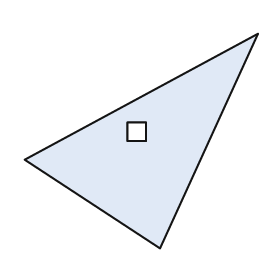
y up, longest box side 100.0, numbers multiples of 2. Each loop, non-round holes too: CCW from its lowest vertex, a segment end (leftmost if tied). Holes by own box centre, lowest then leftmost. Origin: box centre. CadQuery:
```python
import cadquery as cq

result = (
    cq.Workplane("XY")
    .moveTo(8.0, -46.0)
    .lineTo(50.0, 46.0)
    .lineTo(-50.0, -8.0)
    .close()
    .moveTo(-6.0, 0.0)
    .lineTo(2.0, 0.0)
    .lineTo(2.0, 8.0)
    .lineTo(-6.0, 8.0)
    .close()
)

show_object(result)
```